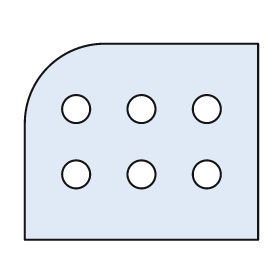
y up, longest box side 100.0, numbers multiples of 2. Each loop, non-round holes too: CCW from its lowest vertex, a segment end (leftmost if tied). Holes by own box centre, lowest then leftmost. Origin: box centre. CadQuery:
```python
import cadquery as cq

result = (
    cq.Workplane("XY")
    .moveTo(-50.0, -42.0)
    .lineTo(50.0, -42.0)
    .lineTo(50.0, 42.0)
    .lineTo(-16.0, 42.0)
    .threePointArc((-40.0, 32.0), (-50.0, 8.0))
    .close()
    .moveTo(-28.0, -14.0)
    .circle(6.0)
    .moveTo(0.0, -14.0)
    .circle(6.0)
    .moveTo(28.0, -14.0)
    .circle(6.0)
    .moveTo(-28.0, 14.0)
    .circle(6.0)
    .moveTo(0.0, 14.0)
    .circle(6.0)
    .moveTo(28.0, 14.0)
    .circle(6.0)
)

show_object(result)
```